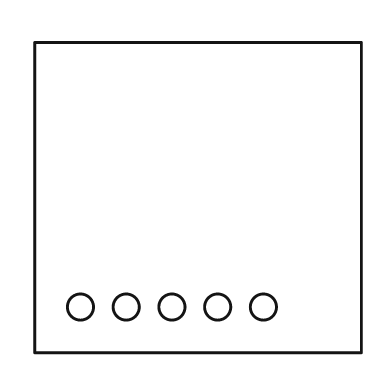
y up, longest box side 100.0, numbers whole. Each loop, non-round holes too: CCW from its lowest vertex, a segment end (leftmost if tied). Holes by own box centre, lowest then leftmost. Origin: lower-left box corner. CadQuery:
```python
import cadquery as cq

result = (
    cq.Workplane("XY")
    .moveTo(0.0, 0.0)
    .lineTo(100.0, 0.0)
    .lineTo(100.0, 95.0)
    .lineTo(0.0, 95.0)
    .close()
    .moveTo(14.0, 14.0)
    .circle(4.0)
    .moveTo(28.0, 14.0)
    .circle(4.0)
    .moveTo(42.0, 14.0)
    .circle(4.0)
    .moveTo(56.0, 14.0)
    .circle(4.0)
    .moveTo(70.0, 14.0)
    .circle(4.0)
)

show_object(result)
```